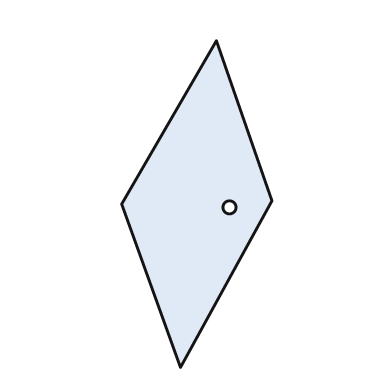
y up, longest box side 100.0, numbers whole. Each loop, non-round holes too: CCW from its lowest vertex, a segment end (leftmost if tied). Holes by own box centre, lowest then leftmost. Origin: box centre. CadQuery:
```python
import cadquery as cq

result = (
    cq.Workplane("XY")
    .moveTo(-5.0, -50.0)
    .lineTo(23.0, 1.0)
    .lineTo(6.0, 50.0)
    .lineTo(-23.0, 0.0)
    .close()
    .moveTo(10.0, -1.0)
    .circle(2.0)
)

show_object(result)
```